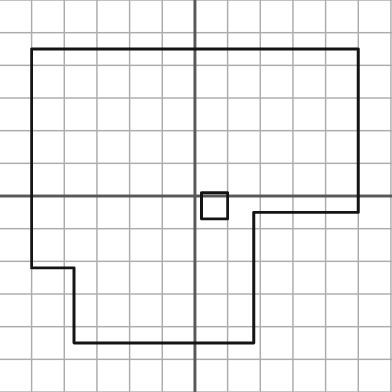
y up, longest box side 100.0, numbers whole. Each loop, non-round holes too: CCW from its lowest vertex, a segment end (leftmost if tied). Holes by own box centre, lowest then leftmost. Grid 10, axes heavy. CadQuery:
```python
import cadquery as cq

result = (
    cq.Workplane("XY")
    .moveTo(-37.0, -45.0)
    .lineTo(18.0, -45.0)
    .lineTo(18.0, -5.0)
    .lineTo(50.0, -5.0)
    .lineTo(50.0, 45.0)
    .lineTo(-50.0, 45.0)
    .lineTo(-50.0, -22.0)
    .lineTo(-37.0, -22.0)
    .close()
    .moveTo(2.0, -7.0)
    .lineTo(10.0, -7.0)
    .lineTo(10.0, 1.0)
    .lineTo(2.0, 1.0)
    .close()
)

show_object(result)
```